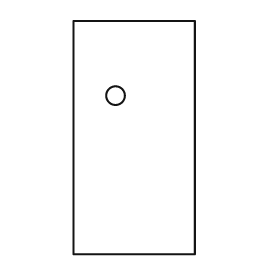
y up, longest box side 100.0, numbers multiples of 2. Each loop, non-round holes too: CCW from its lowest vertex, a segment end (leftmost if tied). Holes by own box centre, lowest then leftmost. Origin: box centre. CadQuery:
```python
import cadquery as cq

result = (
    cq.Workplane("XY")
    .moveTo(-26.0, -50.0)
    .lineTo(26.0, -50.0)
    .lineTo(26.0, 50.0)
    .lineTo(-26.0, 50.0)
    .close()
    .moveTo(-8.0, 18.0)
    .circle(4.0)
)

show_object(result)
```